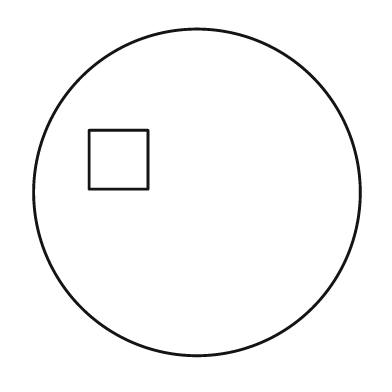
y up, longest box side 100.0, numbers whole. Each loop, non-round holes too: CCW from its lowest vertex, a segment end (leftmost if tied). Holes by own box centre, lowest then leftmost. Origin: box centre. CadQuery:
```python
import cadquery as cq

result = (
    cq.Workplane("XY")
    .moveTo(0.0, 0.0)
    .circle(50.0)
    .moveTo(-33.0, 1.0)
    .lineTo(-15.0, 1.0)
    .lineTo(-15.0, 19.0)
    .lineTo(-33.0, 19.0)
    .close()
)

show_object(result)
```